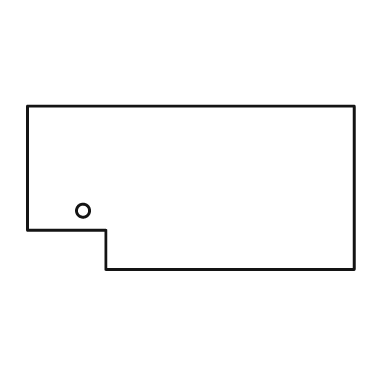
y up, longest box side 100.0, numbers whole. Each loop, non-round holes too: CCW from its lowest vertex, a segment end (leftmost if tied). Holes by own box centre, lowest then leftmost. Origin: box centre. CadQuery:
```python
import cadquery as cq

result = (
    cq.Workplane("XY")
    .moveTo(-26.0, -25.0)
    .lineTo(50.0, -25.0)
    .lineTo(50.0, 25.0)
    .lineTo(-50.0, 25.0)
    .lineTo(-50.0, -13.0)
    .lineTo(-26.0, -13.0)
    .close()
    .moveTo(-33.0, -7.0)
    .circle(2.0)
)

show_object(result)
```